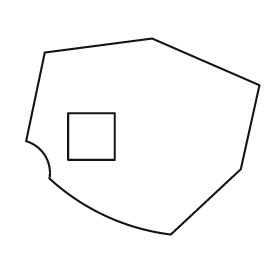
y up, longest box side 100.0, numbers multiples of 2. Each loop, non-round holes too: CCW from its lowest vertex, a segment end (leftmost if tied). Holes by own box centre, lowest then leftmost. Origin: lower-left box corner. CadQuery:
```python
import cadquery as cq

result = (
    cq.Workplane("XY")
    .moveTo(62.0, 0.0)
    .lineTo(92.0, 28.0)
    .lineTo(100.0, 64.0)
    .lineTo(54.0, 84.0)
    .lineTo(8.0, 78.0)
    .lineTo(0.0, 40.0)
    .threePointArc((8.0, 34.0), (10.0, 24.0))
    .threePointArc((34.0, 8.0), (62.0, 0.0))
    .close()
    .moveTo(18.0, 32.0)
    .lineTo(38.0, 32.0)
    .lineTo(38.0, 52.0)
    .lineTo(18.0, 52.0)
    .close()
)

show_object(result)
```